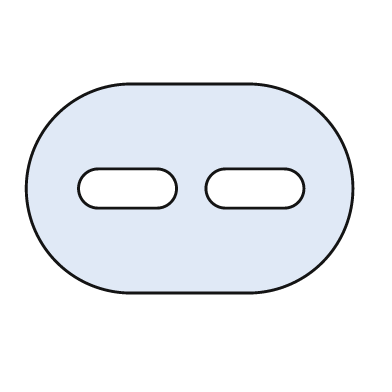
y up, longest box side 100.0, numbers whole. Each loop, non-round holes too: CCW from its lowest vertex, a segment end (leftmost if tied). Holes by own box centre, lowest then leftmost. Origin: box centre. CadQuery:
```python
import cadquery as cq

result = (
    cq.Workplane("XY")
    .moveTo(-18.0, -32.0)
    .lineTo(18.0, -32.0)
    .threePointArc((50.0, 0.0), (18.0, 32.0))
    .lineTo(-18.0, 32.0)
    .threePointArc((-50.0, 0.0), (-18.0, -32.0))
    .close()
    .moveTo(-28.0, -6.0)
    .lineTo(-10.0, -6.0)
    .threePointArc((-4.0, 0.0), (-10.0, 6.0))
    .lineTo(-28.0, 6.0)
    .threePointArc((-34.0, 0.0), (-28.0, -6.0))
    .close()
    .moveTo(11.0, -6.0)
    .lineTo(29.0, -6.0)
    .threePointArc((35.0, 0.0), (29.0, 6.0))
    .lineTo(11.0, 6.0)
    .threePointArc((5.0, 0.0), (11.0, -6.0))
    .close()
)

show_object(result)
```